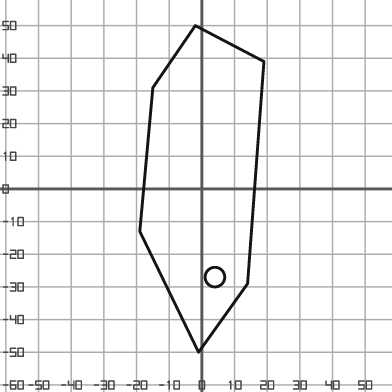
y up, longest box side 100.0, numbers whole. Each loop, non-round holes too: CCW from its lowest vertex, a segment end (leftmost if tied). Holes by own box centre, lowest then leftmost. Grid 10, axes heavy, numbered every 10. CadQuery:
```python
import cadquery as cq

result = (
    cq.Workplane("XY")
    .moveTo(-1.0, -50.0)
    .lineTo(14.0, -29.0)
    .lineTo(19.0, 39.0)
    .lineTo(-2.0, 50.0)
    .lineTo(-15.0, 31.0)
    .lineTo(-19.0, -13.0)
    .close()
    .moveTo(4.0, -27.0)
    .circle(3.0)
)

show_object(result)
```